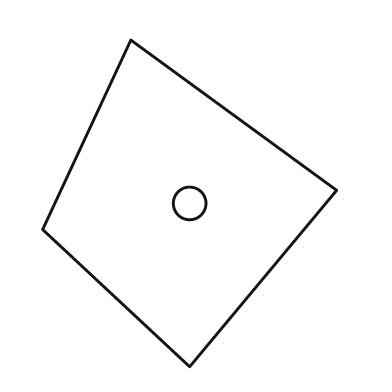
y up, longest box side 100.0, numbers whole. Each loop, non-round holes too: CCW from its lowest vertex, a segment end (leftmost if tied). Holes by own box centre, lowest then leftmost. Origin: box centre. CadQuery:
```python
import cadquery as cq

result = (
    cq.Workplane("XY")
    .moveTo(0.0, -50.0)
    .lineTo(45.0, 4.0)
    .lineTo(-18.0, 50.0)
    .lineTo(-45.0, -8.0)
    .close()
    .moveTo(0.0, 0.0)
    .circle(5.0)
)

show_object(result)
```